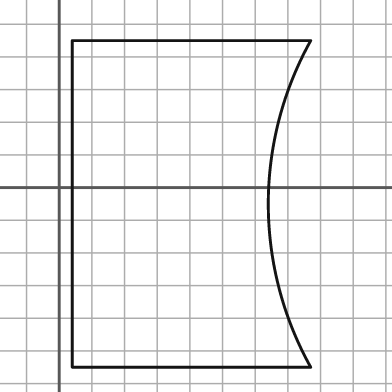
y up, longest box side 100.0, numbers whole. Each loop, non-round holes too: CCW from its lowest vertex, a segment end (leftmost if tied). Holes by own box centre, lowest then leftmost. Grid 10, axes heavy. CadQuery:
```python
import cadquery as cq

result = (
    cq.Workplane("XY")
    .moveTo(4.0, -55.0)
    .lineTo(77.0, -55.0)
    .threePointArc((64.0, -5.0), (77.0, 45.0))
    .lineTo(4.0, 45.0)
    .close()
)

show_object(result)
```